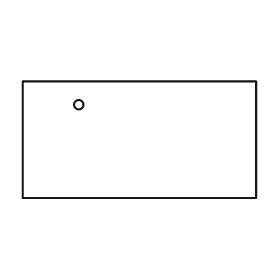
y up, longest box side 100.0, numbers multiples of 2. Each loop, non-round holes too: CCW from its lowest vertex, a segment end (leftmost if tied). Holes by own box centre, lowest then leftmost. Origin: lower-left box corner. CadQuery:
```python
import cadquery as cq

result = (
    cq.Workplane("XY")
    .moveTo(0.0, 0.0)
    .lineTo(100.0, 0.0)
    .lineTo(100.0, 50.0)
    .lineTo(0.0, 50.0)
    .close()
    .moveTo(24.0, 40.0)
    .circle(2.0)
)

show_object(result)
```